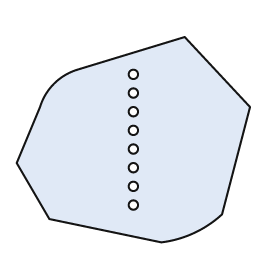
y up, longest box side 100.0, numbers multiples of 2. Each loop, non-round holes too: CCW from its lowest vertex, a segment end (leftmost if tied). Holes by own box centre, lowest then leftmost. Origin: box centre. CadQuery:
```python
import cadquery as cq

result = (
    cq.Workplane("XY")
    .moveTo(12.0, -44.0)
    .threePointArc((26.0, -40.0), (38.0, -32.0))
    .lineTo(50.0, 14.0)
    .lineTo(22.0, 44.0)
    .lineTo(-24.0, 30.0)
    .threePointArc((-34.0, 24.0), (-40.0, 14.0))
    .lineTo(-50.0, -10.0)
    .lineTo(-36.0, -34.0)
    .close()
    .moveTo(0.0, -28.0)
    .circle(2.0)
    .moveTo(0.0, -20.0)
    .circle(2.0)
    .moveTo(0.0, -12.0)
    .circle(2.0)
    .moveTo(0.0, -4.0)
    .circle(2.0)
    .moveTo(0.0, 4.0)
    .circle(2.0)
    .moveTo(0.0, 12.0)
    .circle(2.0)
    .moveTo(0.0, 20.0)
    .circle(2.0)
    .moveTo(0.0, 28.0)
    .circle(2.0)
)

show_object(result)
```